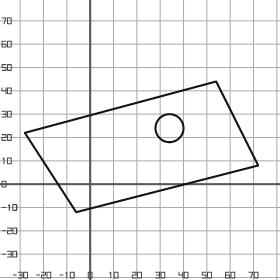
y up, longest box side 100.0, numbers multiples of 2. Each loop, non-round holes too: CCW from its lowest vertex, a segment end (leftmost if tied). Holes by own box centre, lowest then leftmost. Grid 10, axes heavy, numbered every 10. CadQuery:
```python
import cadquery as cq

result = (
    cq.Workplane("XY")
    .moveTo(-6.0, -12.0)
    .lineTo(72.0, 8.0)
    .lineTo(54.0, 44.0)
    .lineTo(-28.0, 22.0)
    .close()
    .moveTo(34.0, 24.0)
    .circle(6.0)
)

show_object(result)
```